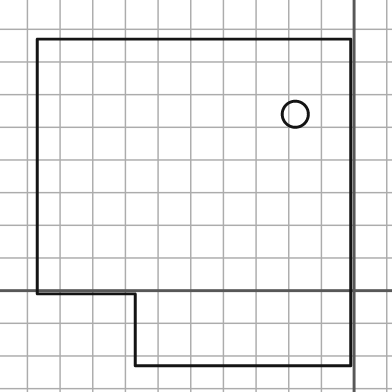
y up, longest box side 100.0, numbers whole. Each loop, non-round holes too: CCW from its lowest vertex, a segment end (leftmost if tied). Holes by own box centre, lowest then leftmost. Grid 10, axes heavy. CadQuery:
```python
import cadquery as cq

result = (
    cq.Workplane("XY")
    .moveTo(-67.0, -23.0)
    .lineTo(-1.0, -23.0)
    .lineTo(-1.0, 77.0)
    .lineTo(-97.0, 77.0)
    .lineTo(-97.0, -1.0)
    .lineTo(-67.0, -1.0)
    .close()
    .moveTo(-18.0, 54.0)
    .circle(4.0)
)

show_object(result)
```